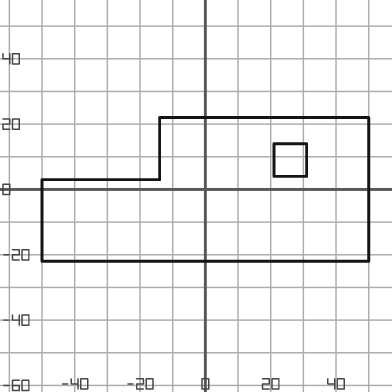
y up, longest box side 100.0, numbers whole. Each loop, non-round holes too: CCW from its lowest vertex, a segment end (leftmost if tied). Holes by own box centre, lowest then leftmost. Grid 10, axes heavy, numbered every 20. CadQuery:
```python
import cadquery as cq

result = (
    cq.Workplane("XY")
    .moveTo(-50.0, -22.0)
    .lineTo(50.0, -22.0)
    .lineTo(50.0, 22.0)
    .lineTo(-14.0, 22.0)
    .lineTo(-14.0, 3.0)
    .lineTo(-50.0, 3.0)
    .close()
    .moveTo(21.0, 4.0)
    .lineTo(31.0, 4.0)
    .lineTo(31.0, 14.0)
    .lineTo(21.0, 14.0)
    .close()
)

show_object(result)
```